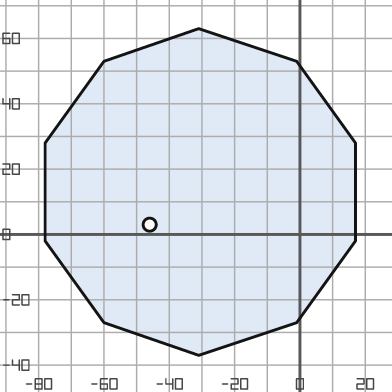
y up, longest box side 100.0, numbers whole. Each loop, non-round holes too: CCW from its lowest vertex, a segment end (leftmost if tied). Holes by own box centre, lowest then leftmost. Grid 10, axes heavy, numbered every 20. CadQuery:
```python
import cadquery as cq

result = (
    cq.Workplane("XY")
    .moveTo(-31.0, -37.0)
    .lineTo(-1.0, -27.0)
    .lineTo(17.0, -2.0)
    .lineTo(17.0, 28.0)
    .lineTo(-1.0, 53.0)
    .lineTo(-31.0, 63.0)
    .lineTo(-60.0, 53.0)
    .lineTo(-78.0, 28.0)
    .lineTo(-78.0, -2.0)
    .lineTo(-60.0, -27.0)
    .close()
    .moveTo(-46.0, 3.0)
    .circle(2.0)
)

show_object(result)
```